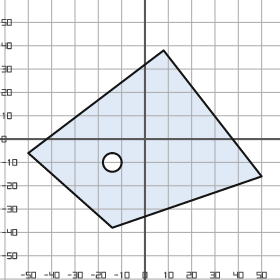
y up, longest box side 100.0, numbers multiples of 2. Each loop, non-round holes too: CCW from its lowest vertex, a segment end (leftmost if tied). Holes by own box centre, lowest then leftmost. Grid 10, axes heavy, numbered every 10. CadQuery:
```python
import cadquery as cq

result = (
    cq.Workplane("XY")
    .moveTo(-14.0, -38.0)
    .lineTo(50.0, -16.0)
    .lineTo(8.0, 38.0)
    .lineTo(-50.0, -6.0)
    .close()
    .moveTo(-14.0, -10.0)
    .circle(4.0)
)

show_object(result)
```